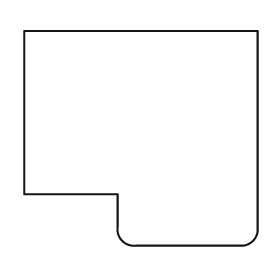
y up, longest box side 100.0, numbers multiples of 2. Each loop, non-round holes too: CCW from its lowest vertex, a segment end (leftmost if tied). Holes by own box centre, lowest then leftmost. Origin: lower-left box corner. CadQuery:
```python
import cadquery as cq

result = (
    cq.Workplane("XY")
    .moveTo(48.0, 0.0)
    .lineTo(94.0, 0.0)
    .threePointArc((98.0, 2.0), (100.0, 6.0))
    .lineTo(100.0, 92.0)
    .lineTo(0.0, 92.0)
    .lineTo(0.0, 22.0)
    .lineTo(40.0, 22.0)
    .lineTo(40.0, 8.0)
    .threePointArc((42.0, 2.0), (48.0, 0.0))
    .close()
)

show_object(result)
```